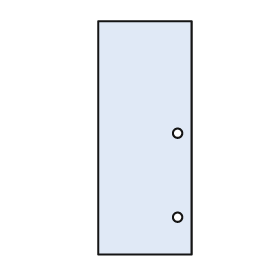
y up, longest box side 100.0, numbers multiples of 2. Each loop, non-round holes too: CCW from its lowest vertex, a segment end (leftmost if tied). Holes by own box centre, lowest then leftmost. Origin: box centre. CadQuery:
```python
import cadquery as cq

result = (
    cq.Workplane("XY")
    .moveTo(-20.0, -50.0)
    .lineTo(20.0, -50.0)
    .lineTo(20.0, 50.0)
    .lineTo(-20.0, 50.0)
    .close()
    .moveTo(14.0, -34.0)
    .circle(2.0)
    .moveTo(14.0, 2.0)
    .circle(2.0)
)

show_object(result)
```